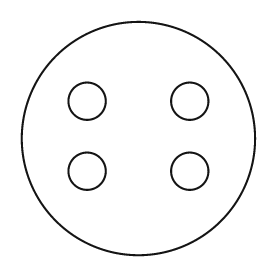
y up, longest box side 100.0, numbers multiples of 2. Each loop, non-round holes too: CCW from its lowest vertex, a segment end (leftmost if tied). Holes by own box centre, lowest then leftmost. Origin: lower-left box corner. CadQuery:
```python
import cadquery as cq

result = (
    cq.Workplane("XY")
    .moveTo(50.0, 50.0)
    .circle(50.0)
    .moveTo(28.0, 36.0)
    .circle(8.0)
    .moveTo(72.0, 36.0)
    .circle(8.0)
    .moveTo(28.0, 66.0)
    .circle(8.0)
    .moveTo(72.0, 66.0)
    .circle(8.0)
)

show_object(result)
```